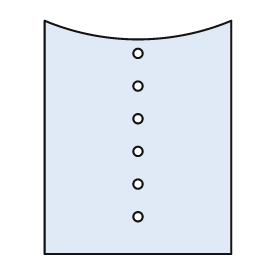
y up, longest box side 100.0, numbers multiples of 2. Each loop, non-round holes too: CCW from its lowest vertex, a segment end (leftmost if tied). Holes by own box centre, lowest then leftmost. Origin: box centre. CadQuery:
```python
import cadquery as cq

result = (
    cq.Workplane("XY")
    .moveTo(-40.0, -50.0)
    .lineTo(40.0, -50.0)
    .lineTo(40.0, 50.0)
    .threePointArc((0.0, 42.0), (-40.0, 50.0))
    .close()
    .moveTo(0.0, -34.0)
    .circle(2.0)
    .moveTo(0.0, -20.0)
    .circle(2.0)
    .moveTo(0.0, -6.0)
    .circle(2.0)
    .moveTo(0.0, 8.0)
    .circle(2.0)
    .moveTo(0.0, 22.0)
    .circle(2.0)
    .moveTo(0.0, 36.0)
    .circle(2.0)
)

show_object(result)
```